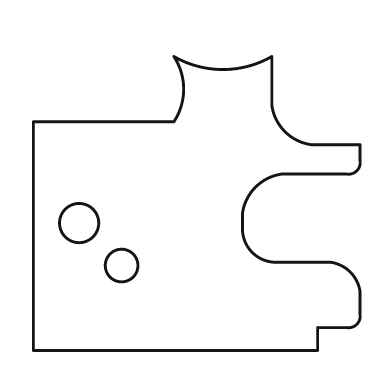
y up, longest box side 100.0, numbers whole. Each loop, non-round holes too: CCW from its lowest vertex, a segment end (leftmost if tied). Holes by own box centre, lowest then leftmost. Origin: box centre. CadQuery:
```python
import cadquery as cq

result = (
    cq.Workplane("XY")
    .moveTo(-50.0, -45.0)
    .lineTo(37.0, -45.0)
    .lineTo(37.0, -38.0)
    .lineTo(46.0, -38.0)
    .threePointArc((49.0, -37.0), (50.0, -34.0))
    .lineTo(50.0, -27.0)
    .threePointArc((47.0, -21.0), (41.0, -18.0))
    .lineTo(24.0, -18.0)
    .threePointArc((17.0, -15.0), (14.0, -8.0))
    .lineTo(14.0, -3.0)
    .threePointArc((18.0, 5.0), (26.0, 9.0))
    .lineTo(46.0, 9.0)
    .threePointArc((49.0, 10.0), (50.0, 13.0))
    .lineTo(50.0, 18.0)
    .lineTo(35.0, 18.0)
    .threePointArc((27.0, 22.0), (23.0, 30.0))
    .lineTo(23.0, 45.0)
    .threePointArc((8.0, 41.0), (-7.0, 45.0))
    .threePointArc((-4.0, 35.0), (-7.0, 25.0))
    .lineTo(-50.0, 25.0)
    .close()
    .moveTo(-23.0, -19.0)
    .circle(5.0)
    .moveTo(-36.0, -6.0)
    .circle(6.0)
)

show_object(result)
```